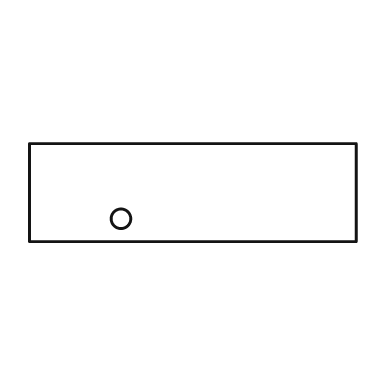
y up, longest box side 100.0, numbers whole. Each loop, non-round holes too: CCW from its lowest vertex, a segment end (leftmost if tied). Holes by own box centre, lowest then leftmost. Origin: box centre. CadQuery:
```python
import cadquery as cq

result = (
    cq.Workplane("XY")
    .moveTo(-50.0, -15.0)
    .lineTo(50.0, -15.0)
    .lineTo(50.0, 15.0)
    .lineTo(-50.0, 15.0)
    .close()
    .moveTo(-22.0, -8.0)
    .circle(3.0)
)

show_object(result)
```